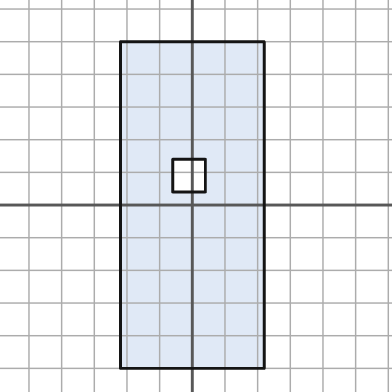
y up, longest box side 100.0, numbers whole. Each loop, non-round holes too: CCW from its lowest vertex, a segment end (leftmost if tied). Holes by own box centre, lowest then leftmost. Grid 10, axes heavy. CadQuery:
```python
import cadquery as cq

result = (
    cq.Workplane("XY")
    .moveTo(-22.0, -50.0)
    .lineTo(22.0, -50.0)
    .lineTo(22.0, 50.0)
    .lineTo(-22.0, 50.0)
    .close()
    .moveTo(-6.0, 4.0)
    .lineTo(4.0, 4.0)
    .lineTo(4.0, 14.0)
    .lineTo(-6.0, 14.0)
    .close()
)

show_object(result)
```